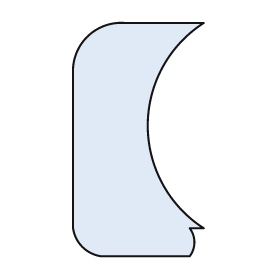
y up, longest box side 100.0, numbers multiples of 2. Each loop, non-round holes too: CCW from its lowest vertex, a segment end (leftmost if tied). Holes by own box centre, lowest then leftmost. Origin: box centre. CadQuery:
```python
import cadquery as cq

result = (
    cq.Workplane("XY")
    .moveTo(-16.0, -50.0)
    .lineTo(22.0, -50.0)
    .threePointArc((24.0, -44.0), (22.0, -38.0))
    .lineTo(28.0, -38.0)
    .threePointArc((4.0, 6.0), (28.0, 50.0))
    .lineTo(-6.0, 50.0)
    .threePointArc((-22.0, 44.0), (-28.0, 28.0))
    .lineTo(-28.0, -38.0)
    .threePointArc((-24.0, -46.0), (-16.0, -50.0))
    .close()
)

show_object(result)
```